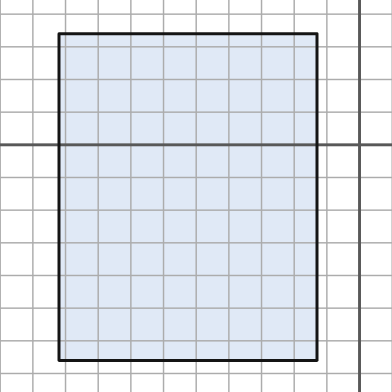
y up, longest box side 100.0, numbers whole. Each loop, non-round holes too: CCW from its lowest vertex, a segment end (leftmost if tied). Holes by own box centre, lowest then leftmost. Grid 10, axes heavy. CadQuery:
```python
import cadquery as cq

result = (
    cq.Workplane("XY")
    .moveTo(-92.0, -66.0)
    .lineTo(-13.0, -66.0)
    .lineTo(-13.0, 34.0)
    .lineTo(-92.0, 34.0)
    .close()
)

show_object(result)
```